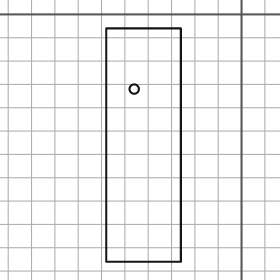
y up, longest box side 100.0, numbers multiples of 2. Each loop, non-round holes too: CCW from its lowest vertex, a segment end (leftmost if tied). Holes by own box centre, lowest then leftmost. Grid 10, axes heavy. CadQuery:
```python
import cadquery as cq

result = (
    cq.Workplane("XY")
    .moveTo(-58.0, -106.0)
    .lineTo(-26.0, -106.0)
    .lineTo(-26.0, -6.0)
    .lineTo(-58.0, -6.0)
    .close()
    .moveTo(-46.0, -32.0)
    .circle(2.0)
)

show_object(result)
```